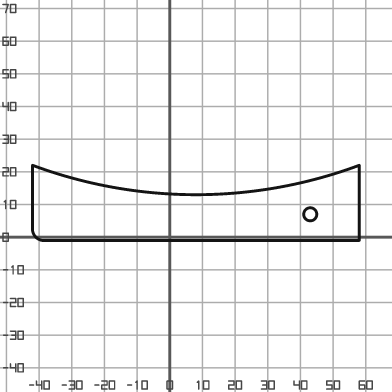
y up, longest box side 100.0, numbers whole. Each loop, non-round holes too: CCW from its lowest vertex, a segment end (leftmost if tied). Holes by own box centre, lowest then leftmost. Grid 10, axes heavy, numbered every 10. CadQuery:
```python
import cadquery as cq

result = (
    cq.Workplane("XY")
    .moveTo(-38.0, -1.0)
    .lineTo(58.0, -1.0)
    .lineTo(58.0, 22.0)
    .threePointArc((8.0, 13.0), (-42.0, 22.0))
    .lineTo(-42.0, 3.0)
    .threePointArc((-41.0, 0.0), (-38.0, -1.0))
    .close()
    .moveTo(43.0, 7.0)
    .circle(2.0)
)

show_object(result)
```